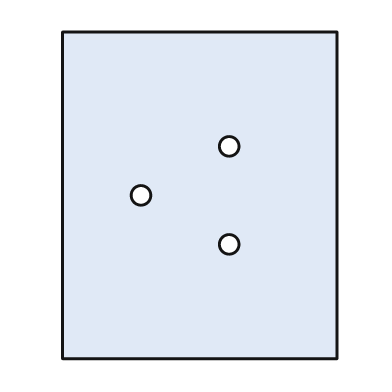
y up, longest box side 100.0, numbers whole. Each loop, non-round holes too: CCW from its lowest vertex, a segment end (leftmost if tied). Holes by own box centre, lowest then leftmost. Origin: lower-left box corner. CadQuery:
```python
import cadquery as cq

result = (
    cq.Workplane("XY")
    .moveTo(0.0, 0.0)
    .lineTo(84.0, 0.0)
    .lineTo(84.0, 100.0)
    .lineTo(0.0, 100.0)
    .close()
    .moveTo(51.0, 35.0)
    .circle(3.0)
    .moveTo(24.0, 50.0)
    .circle(3.0)
    .moveTo(51.0, 65.0)
    .circle(3.0)
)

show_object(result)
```